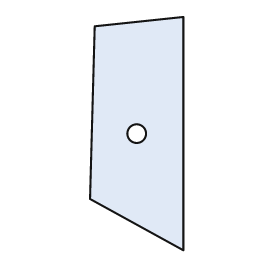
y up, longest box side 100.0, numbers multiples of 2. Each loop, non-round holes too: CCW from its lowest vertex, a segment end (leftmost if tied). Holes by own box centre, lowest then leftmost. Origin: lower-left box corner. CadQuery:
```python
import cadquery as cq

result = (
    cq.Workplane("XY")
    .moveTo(40.0, 0.0)
    .lineTo(40.0, 100.0)
    .lineTo(2.0, 96.0)
    .lineTo(0.0, 22.0)
    .close()
    .moveTo(20.0, 50.0)
    .circle(4.0)
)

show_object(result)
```